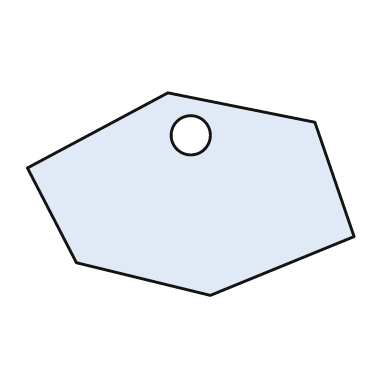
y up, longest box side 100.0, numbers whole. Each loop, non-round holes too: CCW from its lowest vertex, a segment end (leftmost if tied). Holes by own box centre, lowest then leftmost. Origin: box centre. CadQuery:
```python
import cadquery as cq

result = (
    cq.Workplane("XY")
    .moveTo(6.0, -31.0)
    .lineTo(50.0, -13.0)
    .lineTo(38.0, 22.0)
    .lineTo(-7.0, 31.0)
    .lineTo(-50.0, 8.0)
    .lineTo(-35.0, -21.0)
    .close()
    .moveTo(0.0, 18.0)
    .circle(6.0)
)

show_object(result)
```